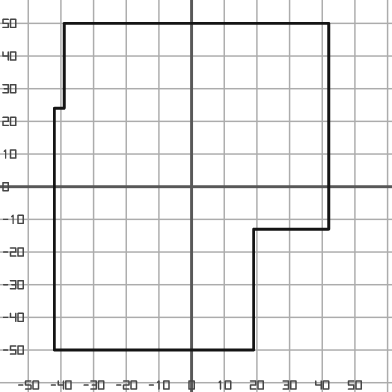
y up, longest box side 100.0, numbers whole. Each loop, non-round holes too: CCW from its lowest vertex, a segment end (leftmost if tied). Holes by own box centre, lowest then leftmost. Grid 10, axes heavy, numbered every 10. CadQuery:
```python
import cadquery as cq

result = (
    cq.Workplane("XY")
    .moveTo(-42.0, -50.0)
    .lineTo(19.0, -50.0)
    .lineTo(19.0, -13.0)
    .lineTo(42.0, -13.0)
    .lineTo(42.0, 50.0)
    .lineTo(-39.0, 50.0)
    .lineTo(-39.0, 24.0)
    .lineTo(-42.0, 24.0)
    .close()
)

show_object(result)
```